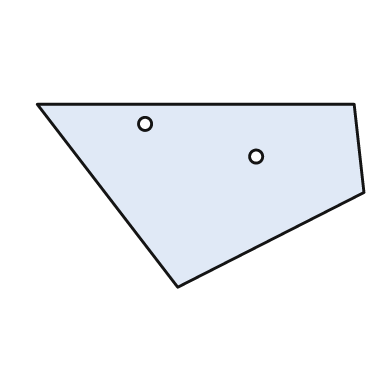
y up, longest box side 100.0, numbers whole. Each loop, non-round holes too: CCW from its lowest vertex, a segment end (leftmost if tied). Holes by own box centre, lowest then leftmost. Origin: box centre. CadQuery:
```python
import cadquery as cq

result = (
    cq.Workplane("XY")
    .moveTo(-7.0, -28.0)
    .lineTo(50.0, 1.0)
    .lineTo(47.0, 28.0)
    .lineTo(-50.0, 28.0)
    .close()
    .moveTo(17.0, 12.0)
    .circle(2.0)
    .moveTo(-17.0, 22.0)
    .circle(2.0)
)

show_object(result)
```